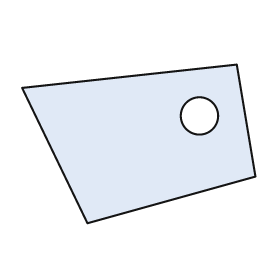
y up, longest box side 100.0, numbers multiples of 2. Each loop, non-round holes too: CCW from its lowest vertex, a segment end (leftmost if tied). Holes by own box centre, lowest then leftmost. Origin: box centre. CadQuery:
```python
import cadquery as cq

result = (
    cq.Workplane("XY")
    .moveTo(-22.0, -34.0)
    .lineTo(50.0, -14.0)
    .lineTo(42.0, 34.0)
    .lineTo(-50.0, 24.0)
    .close()
    .moveTo(26.0, 12.0)
    .circle(8.0)
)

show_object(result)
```